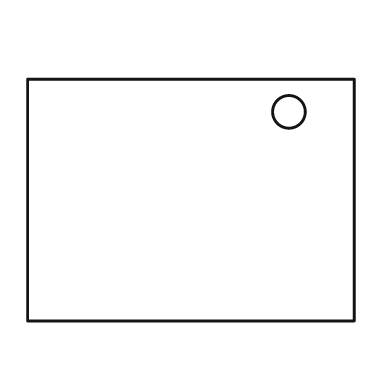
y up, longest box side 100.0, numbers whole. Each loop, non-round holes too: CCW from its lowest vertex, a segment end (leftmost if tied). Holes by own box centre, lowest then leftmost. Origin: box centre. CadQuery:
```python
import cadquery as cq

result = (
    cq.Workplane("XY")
    .moveTo(-50.0, -37.0)
    .lineTo(50.0, -37.0)
    .lineTo(50.0, 37.0)
    .lineTo(-50.0, 37.0)
    .close()
    .moveTo(30.0, 27.0)
    .circle(5.0)
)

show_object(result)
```